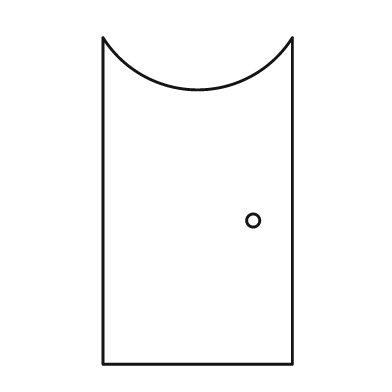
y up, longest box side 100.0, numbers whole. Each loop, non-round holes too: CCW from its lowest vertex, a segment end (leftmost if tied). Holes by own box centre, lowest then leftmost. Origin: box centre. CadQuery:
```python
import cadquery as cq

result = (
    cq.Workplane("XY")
    .moveTo(-29.0, -50.0)
    .lineTo(29.0, -50.0)
    .lineTo(29.0, 50.0)
    .threePointArc((0.0, 34.0), (-29.0, 50.0))
    .close()
    .moveTo(17.0, -6.0)
    .circle(2.0)
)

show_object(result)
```